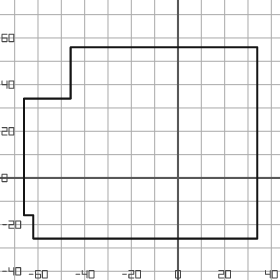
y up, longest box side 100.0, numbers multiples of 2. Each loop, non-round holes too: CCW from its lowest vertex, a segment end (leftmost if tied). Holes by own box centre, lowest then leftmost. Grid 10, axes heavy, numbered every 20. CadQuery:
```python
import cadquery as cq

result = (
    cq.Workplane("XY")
    .moveTo(-62.0, -26.0)
    .lineTo(34.0, -26.0)
    .lineTo(34.0, 56.0)
    .lineTo(-46.0, 56.0)
    .lineTo(-46.0, 34.0)
    .lineTo(-66.0, 34.0)
    .lineTo(-66.0, -16.0)
    .lineTo(-62.0, -16.0)
    .close()
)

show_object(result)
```